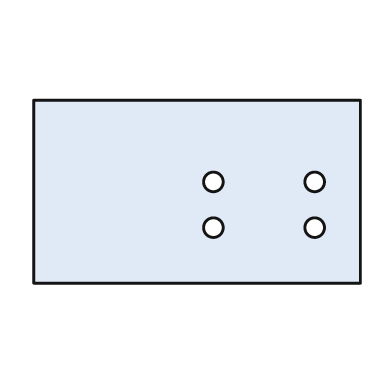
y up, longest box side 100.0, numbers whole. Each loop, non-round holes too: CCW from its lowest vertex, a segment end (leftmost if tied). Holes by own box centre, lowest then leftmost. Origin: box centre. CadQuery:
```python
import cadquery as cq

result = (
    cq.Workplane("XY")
    .moveTo(-50.0, -28.0)
    .lineTo(50.0, -28.0)
    .lineTo(50.0, 28.0)
    .lineTo(-50.0, 28.0)
    .close()
    .moveTo(5.0, -11.0)
    .circle(3.0)
    .moveTo(36.0, -11.0)
    .circle(3.0)
    .moveTo(5.0, 3.0)
    .circle(3.0)
    .moveTo(36.0, 3.0)
    .circle(3.0)
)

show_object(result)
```